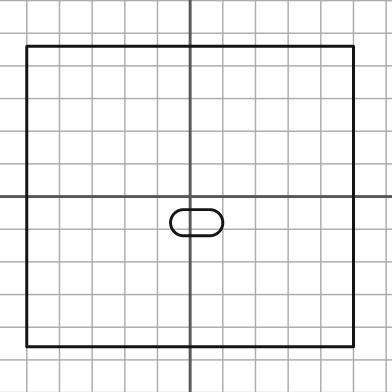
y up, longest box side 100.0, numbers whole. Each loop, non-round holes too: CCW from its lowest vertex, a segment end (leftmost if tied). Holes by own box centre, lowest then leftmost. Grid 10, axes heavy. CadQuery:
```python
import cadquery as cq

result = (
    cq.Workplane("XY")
    .moveTo(-50.0, -46.0)
    .lineTo(50.0, -46.0)
    .lineTo(50.0, 46.0)
    .lineTo(-50.0, 46.0)
    .close()
    .moveTo(-2.0, -12.0)
    .lineTo(6.0, -12.0)
    .threePointArc((10.0, -8.0), (6.0, -4.0))
    .lineTo(-2.0, -4.0)
    .threePointArc((-6.0, -8.0), (-2.0, -12.0))
    .close()
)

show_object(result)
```